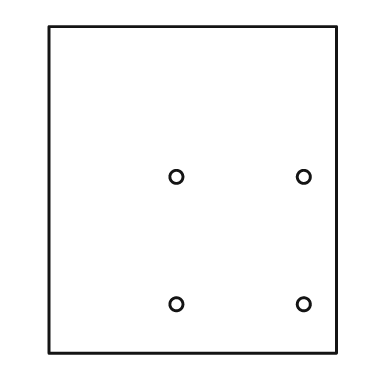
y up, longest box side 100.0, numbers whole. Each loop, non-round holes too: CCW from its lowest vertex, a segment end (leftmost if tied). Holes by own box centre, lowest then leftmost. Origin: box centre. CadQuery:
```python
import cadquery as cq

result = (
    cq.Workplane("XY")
    .moveTo(-44.0, -50.0)
    .lineTo(44.0, -50.0)
    .lineTo(44.0, 50.0)
    .lineTo(-44.0, 50.0)
    .close()
    .moveTo(-5.0, -35.0)
    .circle(2.0)
    .moveTo(34.0, -35.0)
    .circle(2.0)
    .moveTo(-5.0, 4.0)
    .circle(2.0)
    .moveTo(34.0, 4.0)
    .circle(2.0)
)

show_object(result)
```